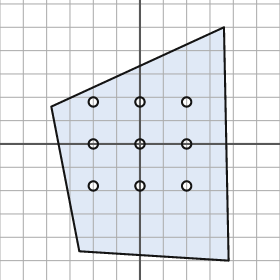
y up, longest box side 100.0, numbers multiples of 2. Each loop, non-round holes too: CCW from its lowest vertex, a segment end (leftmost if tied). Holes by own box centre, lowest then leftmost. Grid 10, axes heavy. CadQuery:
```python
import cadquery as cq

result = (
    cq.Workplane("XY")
    .moveTo(38.0, -50.0)
    .lineTo(36.0, 50.0)
    .lineTo(-38.0, 16.0)
    .lineTo(-26.0, -46.0)
    .close()
    .moveTo(-20.0, -18.0)
    .circle(2.0)
    .moveTo(0.0, -18.0)
    .circle(2.0)
    .moveTo(20.0, -18.0)
    .circle(2.0)
    .moveTo(-20.0, 0.0)
    .circle(2.0)
    .moveTo(0.0, 0.0)
    .circle(2.0)
    .moveTo(20.0, 0.0)
    .circle(2.0)
    .moveTo(-20.0, 18.0)
    .circle(2.0)
    .moveTo(0.0, 18.0)
    .circle(2.0)
    .moveTo(20.0, 18.0)
    .circle(2.0)
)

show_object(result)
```